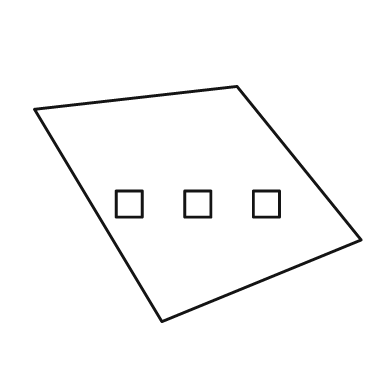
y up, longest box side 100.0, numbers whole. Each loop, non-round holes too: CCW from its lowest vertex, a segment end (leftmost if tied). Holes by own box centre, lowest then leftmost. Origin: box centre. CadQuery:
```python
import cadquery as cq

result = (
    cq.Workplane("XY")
    .moveTo(-11.0, -36.0)
    .lineTo(50.0, -11.0)
    .lineTo(12.0, 36.0)
    .lineTo(-50.0, 29.0)
    .close()
    .moveTo(-25.0, -4.0)
    .lineTo(-17.0, -4.0)
    .lineTo(-17.0, 4.0)
    .lineTo(-25.0, 4.0)
    .close()
    .moveTo(-4.0, -4.0)
    .lineTo(4.0, -4.0)
    .lineTo(4.0, 4.0)
    .lineTo(-4.0, 4.0)
    .close()
    .moveTo(17.0, -4.0)
    .lineTo(25.0, -4.0)
    .lineTo(25.0, 4.0)
    .lineTo(17.0, 4.0)
    .close()
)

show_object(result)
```